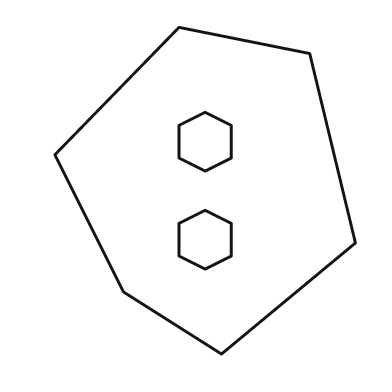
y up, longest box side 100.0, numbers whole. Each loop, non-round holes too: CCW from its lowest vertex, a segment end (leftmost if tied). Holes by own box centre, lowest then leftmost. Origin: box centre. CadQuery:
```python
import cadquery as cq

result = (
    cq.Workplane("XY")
    .moveTo(5.0, -50.0)
    .lineTo(46.0, -16.0)
    .lineTo(32.0, 42.0)
    .lineTo(-8.0, 50.0)
    .lineTo(-46.0, 11.0)
    .lineTo(-25.0, -31.0)
    .close()
    .moveTo(0.0, -24.0)
    .lineTo(8.0, -20.0)
    .lineTo(8.0, -10.0)
    .lineTo(0.0, -6.0)
    .lineTo(-8.0, -10.0)
    .lineTo(-8.0, -20.0)
    .close()
    .moveTo(0.0, 6.0)
    .lineTo(8.0, 10.0)
    .lineTo(8.0, 20.0)
    .lineTo(0.0, 24.0)
    .lineTo(-8.0, 20.0)
    .lineTo(-8.0, 10.0)
    .close()
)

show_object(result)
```